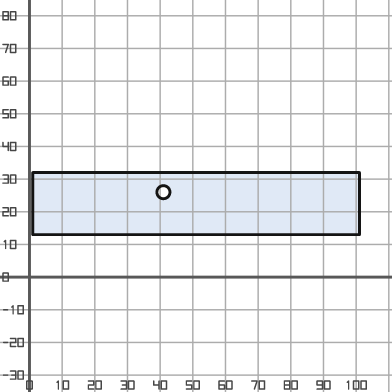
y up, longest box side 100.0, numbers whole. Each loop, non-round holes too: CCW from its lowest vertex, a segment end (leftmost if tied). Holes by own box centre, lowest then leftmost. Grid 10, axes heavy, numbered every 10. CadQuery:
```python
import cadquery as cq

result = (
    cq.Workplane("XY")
    .moveTo(1.0, 13.0)
    .lineTo(101.0, 13.0)
    .lineTo(101.0, 32.0)
    .lineTo(1.0, 32.0)
    .close()
    .moveTo(41.0, 26.0)
    .circle(2.0)
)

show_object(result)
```